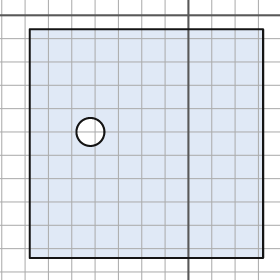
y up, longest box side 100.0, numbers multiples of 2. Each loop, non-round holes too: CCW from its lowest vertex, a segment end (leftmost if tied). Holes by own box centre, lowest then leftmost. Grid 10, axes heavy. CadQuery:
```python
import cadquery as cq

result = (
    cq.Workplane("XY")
    .moveTo(-68.0, -104.0)
    .lineTo(32.0, -104.0)
    .lineTo(32.0, -6.0)
    .lineTo(-68.0, -6.0)
    .close()
    .moveTo(-42.0, -50.0)
    .circle(6.0)
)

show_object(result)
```